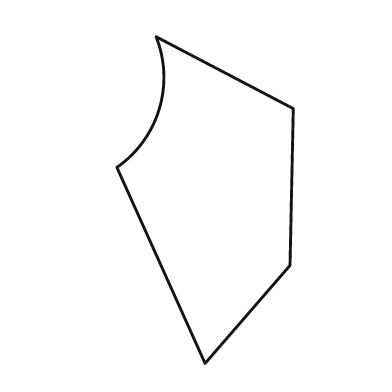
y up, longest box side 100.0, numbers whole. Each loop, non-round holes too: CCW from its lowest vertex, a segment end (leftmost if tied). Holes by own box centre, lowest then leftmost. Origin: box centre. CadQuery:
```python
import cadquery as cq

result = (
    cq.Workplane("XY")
    .moveTo(0.0, -50.0)
    .lineTo(26.0, -20.0)
    .lineTo(27.0, 28.0)
    .lineTo(-15.0, 50.0)
    .threePointArc((-14.0, 28.0), (-27.0, 10.0))
    .close()
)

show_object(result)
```